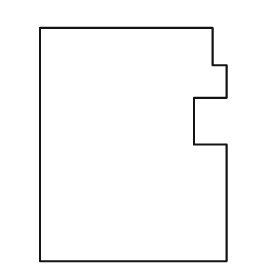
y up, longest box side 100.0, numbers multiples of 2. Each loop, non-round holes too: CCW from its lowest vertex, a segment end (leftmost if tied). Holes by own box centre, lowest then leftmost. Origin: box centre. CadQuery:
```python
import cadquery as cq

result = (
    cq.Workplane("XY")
    .moveTo(-40.0, -50.0)
    .lineTo(40.0, -50.0)
    .lineTo(40.0, 0.0)
    .lineTo(26.0, 0.0)
    .lineTo(26.0, 20.0)
    .lineTo(40.0, 20.0)
    .lineTo(40.0, 34.0)
    .lineTo(34.0, 34.0)
    .lineTo(34.0, 50.0)
    .lineTo(-40.0, 50.0)
    .close()
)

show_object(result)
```